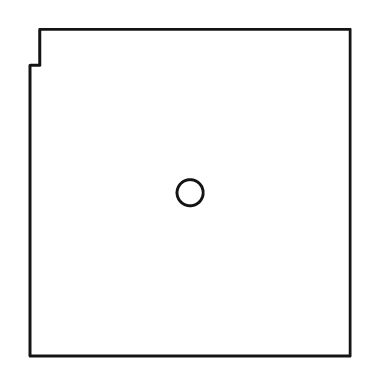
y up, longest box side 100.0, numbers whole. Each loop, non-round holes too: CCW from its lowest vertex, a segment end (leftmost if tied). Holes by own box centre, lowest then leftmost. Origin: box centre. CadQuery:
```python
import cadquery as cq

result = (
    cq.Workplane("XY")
    .moveTo(-49.0, -50.0)
    .lineTo(49.0, -50.0)
    .lineTo(49.0, 50.0)
    .lineTo(-46.0, 50.0)
    .lineTo(-46.0, 39.0)
    .lineTo(-49.0, 39.0)
    .close()
    .moveTo(0.0, 0.0)
    .circle(4.0)
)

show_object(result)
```